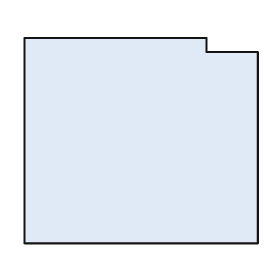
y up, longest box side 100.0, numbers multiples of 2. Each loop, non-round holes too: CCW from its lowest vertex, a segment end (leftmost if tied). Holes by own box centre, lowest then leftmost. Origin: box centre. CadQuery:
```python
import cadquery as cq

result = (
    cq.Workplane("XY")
    .moveTo(-50.0, -44.0)
    .lineTo(50.0, -44.0)
    .lineTo(50.0, 38.0)
    .lineTo(28.0, 38.0)
    .lineTo(28.0, 44.0)
    .lineTo(-50.0, 44.0)
    .close()
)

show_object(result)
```